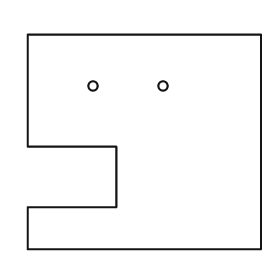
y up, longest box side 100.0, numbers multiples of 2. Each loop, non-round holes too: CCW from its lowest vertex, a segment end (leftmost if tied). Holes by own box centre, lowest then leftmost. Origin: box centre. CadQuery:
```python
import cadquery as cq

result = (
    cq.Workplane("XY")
    .moveTo(-50.0, -46.0)
    .lineTo(50.0, -46.0)
    .lineTo(50.0, 46.0)
    .lineTo(-50.0, 46.0)
    .lineTo(-50.0, -2.0)
    .lineTo(-12.0, -2.0)
    .lineTo(-12.0, -28.0)
    .lineTo(-50.0, -28.0)
    .close()
    .moveTo(-22.0, 24.0)
    .circle(2.0)
    .moveTo(8.0, 24.0)
    .circle(2.0)
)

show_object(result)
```